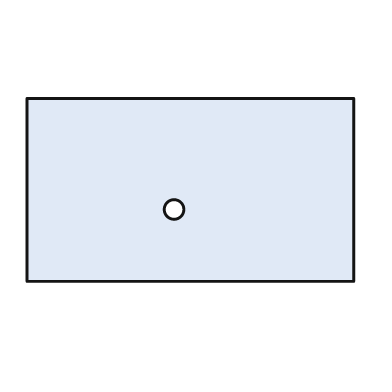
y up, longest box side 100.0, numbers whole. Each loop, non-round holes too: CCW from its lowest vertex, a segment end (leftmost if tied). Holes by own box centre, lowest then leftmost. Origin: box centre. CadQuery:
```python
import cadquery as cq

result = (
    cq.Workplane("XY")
    .moveTo(-50.0, -28.0)
    .lineTo(50.0, -28.0)
    .lineTo(50.0, 28.0)
    .lineTo(-50.0, 28.0)
    .close()
    .moveTo(-5.0, -6.0)
    .circle(3.0)
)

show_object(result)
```